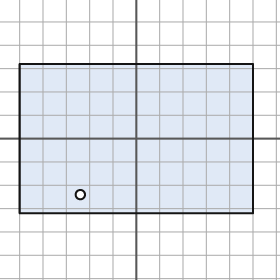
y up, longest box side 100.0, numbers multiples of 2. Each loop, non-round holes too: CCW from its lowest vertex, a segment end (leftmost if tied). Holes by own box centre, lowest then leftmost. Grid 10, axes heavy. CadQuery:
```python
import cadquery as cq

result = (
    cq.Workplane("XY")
    .moveTo(-50.0, -32.0)
    .lineTo(50.0, -32.0)
    .lineTo(50.0, 32.0)
    .lineTo(-50.0, 32.0)
    .close()
    .moveTo(-24.0, -24.0)
    .circle(2.0)
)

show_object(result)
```